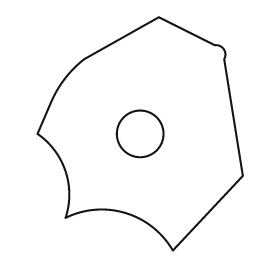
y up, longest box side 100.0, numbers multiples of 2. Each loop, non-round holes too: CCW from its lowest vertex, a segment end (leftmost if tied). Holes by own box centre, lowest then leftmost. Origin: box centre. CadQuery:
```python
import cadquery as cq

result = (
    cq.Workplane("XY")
    .moveTo(14.0, -50.0)
    .lineTo(44.0, -18.0)
    .lineTo(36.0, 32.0)
    .threePointArc((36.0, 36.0), (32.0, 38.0))
    .lineTo(8.0, 50.0)
    .lineTo(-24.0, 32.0)
    .threePointArc((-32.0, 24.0), (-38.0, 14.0))
    .lineTo(-44.0, 0.0)
    .threePointArc((-32.0, -16.0), (-32.0, -36.0))
    .threePointArc((-6.0, -34.0), (14.0, -50.0))
    .close()
    .moveTo(0.0, 0.0)
    .circle(10.0)
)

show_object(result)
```